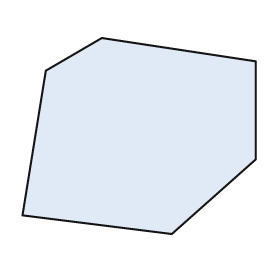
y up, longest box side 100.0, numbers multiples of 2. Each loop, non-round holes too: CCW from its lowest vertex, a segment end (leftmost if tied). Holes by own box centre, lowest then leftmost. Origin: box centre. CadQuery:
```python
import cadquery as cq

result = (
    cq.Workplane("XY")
    .moveTo(14.0, -42.0)
    .lineTo(50.0, -10.0)
    .lineTo(50.0, 32.0)
    .lineTo(-16.0, 42.0)
    .lineTo(-40.0, 28.0)
    .lineTo(-50.0, -34.0)
    .close()
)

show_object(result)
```